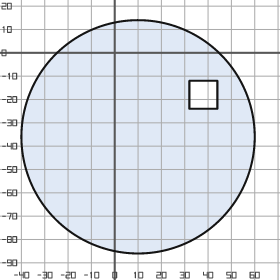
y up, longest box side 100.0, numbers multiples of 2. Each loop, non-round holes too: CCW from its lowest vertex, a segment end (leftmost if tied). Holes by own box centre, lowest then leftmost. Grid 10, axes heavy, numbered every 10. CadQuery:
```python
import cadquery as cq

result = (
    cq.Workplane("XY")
    .moveTo(10.0, -36.0)
    .circle(50.0)
    .moveTo(32.0, -24.0)
    .lineTo(44.0, -24.0)
    .lineTo(44.0, -12.0)
    .lineTo(32.0, -12.0)
    .close()
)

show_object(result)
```